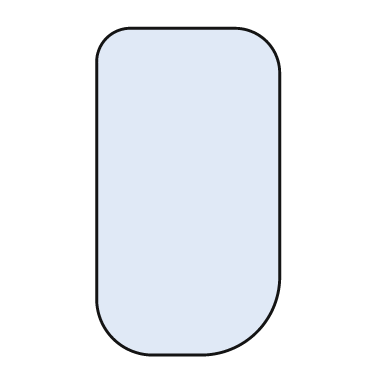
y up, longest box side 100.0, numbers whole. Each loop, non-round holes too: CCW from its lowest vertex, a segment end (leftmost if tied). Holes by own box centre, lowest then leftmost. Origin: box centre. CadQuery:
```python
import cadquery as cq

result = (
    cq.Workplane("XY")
    .moveTo(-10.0, -50.0)
    .lineTo(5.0, -50.0)
    .threePointArc((21.0, -43.0), (28.0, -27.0))
    .lineTo(28.0, 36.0)
    .threePointArc((24.0, 46.0), (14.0, 50.0))
    .lineTo(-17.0, 50.0)
    .threePointArc((-25.0, 47.0), (-28.0, 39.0))
    .lineTo(-28.0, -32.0)
    .threePointArc((-23.0, -45.0), (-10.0, -50.0))
    .close()
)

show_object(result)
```